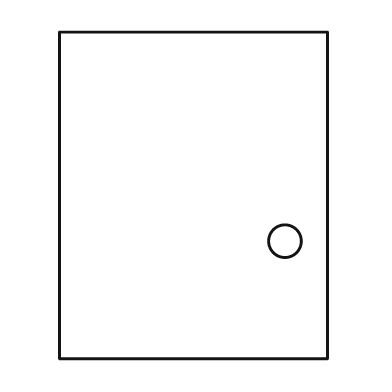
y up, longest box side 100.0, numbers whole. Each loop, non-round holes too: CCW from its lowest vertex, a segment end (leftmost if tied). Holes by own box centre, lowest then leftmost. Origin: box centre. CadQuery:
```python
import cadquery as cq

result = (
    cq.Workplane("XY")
    .moveTo(-41.0, -50.0)
    .lineTo(41.0, -50.0)
    .lineTo(41.0, 50.0)
    .lineTo(-41.0, 50.0)
    .close()
    .moveTo(28.0, -14.0)
    .circle(5.0)
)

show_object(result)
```